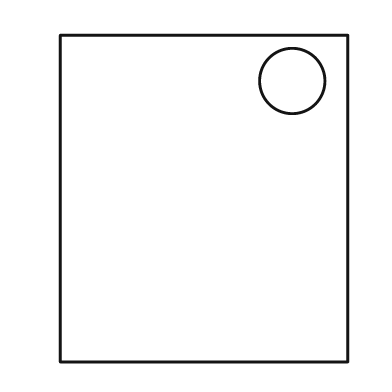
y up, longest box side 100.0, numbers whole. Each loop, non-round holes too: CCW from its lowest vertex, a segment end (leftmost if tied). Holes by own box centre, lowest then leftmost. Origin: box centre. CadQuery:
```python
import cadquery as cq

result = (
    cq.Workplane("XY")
    .moveTo(-44.0, -50.0)
    .lineTo(44.0, -50.0)
    .lineTo(44.0, 50.0)
    .lineTo(-44.0, 50.0)
    .close()
    .moveTo(27.0, 36.0)
    .circle(10.0)
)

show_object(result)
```